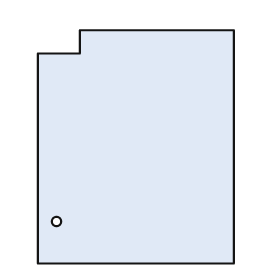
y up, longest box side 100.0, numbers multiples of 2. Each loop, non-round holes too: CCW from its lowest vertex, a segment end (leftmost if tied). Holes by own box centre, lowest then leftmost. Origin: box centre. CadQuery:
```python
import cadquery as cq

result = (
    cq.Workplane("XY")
    .moveTo(-42.0, -50.0)
    .lineTo(42.0, -50.0)
    .lineTo(42.0, 50.0)
    .lineTo(-24.0, 50.0)
    .lineTo(-24.0, 40.0)
    .lineTo(-42.0, 40.0)
    .close()
    .moveTo(-34.0, -32.0)
    .circle(2.0)
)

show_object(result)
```